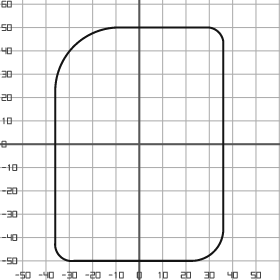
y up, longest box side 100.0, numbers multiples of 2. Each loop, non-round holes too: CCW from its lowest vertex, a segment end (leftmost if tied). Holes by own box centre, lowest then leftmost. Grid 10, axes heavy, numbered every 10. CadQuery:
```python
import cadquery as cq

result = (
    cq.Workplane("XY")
    .moveTo(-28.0, -50.0)
    .lineTo(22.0, -50.0)
    .threePointArc((32.0, -46.0), (36.0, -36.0))
    .lineTo(36.0, 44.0)
    .threePointArc((34.0, 48.0), (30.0, 50.0))
    .lineTo(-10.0, 50.0)
    .threePointArc((-28.0, 42.0), (-36.0, 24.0))
    .lineTo(-36.0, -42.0)
    .threePointArc((-34.0, -48.0), (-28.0, -50.0))
    .close()
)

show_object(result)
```